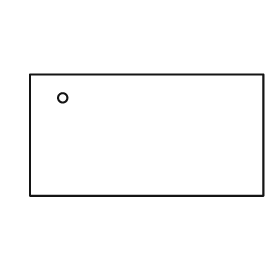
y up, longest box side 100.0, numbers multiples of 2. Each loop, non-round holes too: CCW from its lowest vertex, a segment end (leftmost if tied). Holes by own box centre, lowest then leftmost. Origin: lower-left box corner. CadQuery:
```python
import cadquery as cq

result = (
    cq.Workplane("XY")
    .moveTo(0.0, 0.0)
    .lineTo(100.0, 0.0)
    .lineTo(100.0, 52.0)
    .lineTo(0.0, 52.0)
    .close()
    .moveTo(14.0, 42.0)
    .circle(2.0)
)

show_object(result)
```